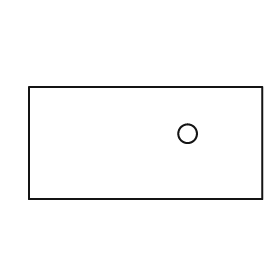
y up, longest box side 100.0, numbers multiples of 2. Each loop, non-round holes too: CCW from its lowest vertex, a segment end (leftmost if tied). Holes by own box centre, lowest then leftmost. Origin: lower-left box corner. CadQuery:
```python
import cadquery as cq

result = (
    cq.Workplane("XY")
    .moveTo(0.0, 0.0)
    .lineTo(100.0, 0.0)
    .lineTo(100.0, 48.0)
    .lineTo(0.0, 48.0)
    .close()
    .moveTo(68.0, 28.0)
    .circle(4.0)
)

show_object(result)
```